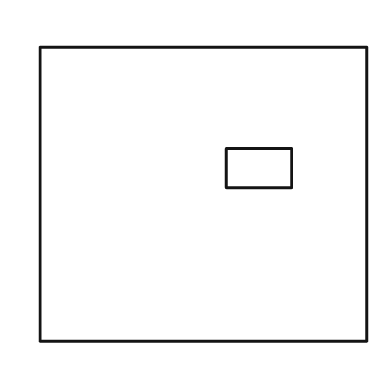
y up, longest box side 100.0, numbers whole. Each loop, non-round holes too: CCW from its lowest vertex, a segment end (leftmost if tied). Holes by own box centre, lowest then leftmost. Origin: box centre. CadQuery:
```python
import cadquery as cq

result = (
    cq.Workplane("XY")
    .moveTo(-50.0, -45.0)
    .lineTo(50.0, -45.0)
    .lineTo(50.0, 45.0)
    .lineTo(-50.0, 45.0)
    .close()
    .moveTo(7.0, 2.0)
    .lineTo(27.0, 2.0)
    .lineTo(27.0, 14.0)
    .lineTo(7.0, 14.0)
    .close()
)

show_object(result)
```